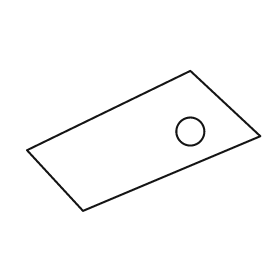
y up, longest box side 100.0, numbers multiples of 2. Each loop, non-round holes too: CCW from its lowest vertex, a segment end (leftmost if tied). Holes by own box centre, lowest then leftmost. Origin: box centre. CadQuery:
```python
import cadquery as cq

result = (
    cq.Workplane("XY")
    .moveTo(-26.0, -30.0)
    .lineTo(50.0, 2.0)
    .lineTo(20.0, 30.0)
    .lineTo(-50.0, -4.0)
    .close()
    .moveTo(20.0, 4.0)
    .circle(6.0)
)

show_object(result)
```